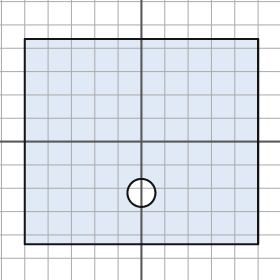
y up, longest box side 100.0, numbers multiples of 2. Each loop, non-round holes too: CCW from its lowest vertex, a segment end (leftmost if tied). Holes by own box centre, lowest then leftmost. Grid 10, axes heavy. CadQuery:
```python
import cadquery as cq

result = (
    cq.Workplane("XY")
    .moveTo(-50.0, -44.0)
    .lineTo(50.0, -44.0)
    .lineTo(50.0, 44.0)
    .lineTo(-50.0, 44.0)
    .close()
    .moveTo(0.0, -22.0)
    .circle(6.0)
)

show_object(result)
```